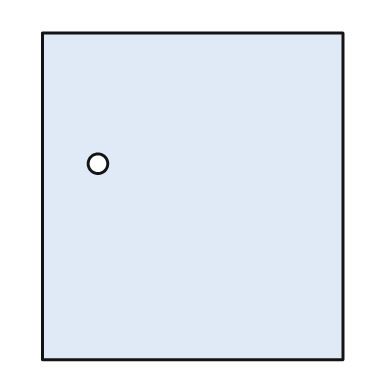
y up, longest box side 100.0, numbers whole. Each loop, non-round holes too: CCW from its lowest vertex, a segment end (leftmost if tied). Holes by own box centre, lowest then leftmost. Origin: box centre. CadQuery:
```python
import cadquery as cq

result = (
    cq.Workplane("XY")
    .moveTo(-46.0, -50.0)
    .lineTo(46.0, -50.0)
    .lineTo(46.0, 50.0)
    .lineTo(-46.0, 50.0)
    .close()
    .moveTo(-29.0, 10.0)
    .circle(3.0)
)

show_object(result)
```